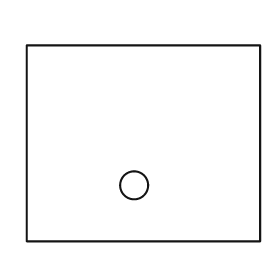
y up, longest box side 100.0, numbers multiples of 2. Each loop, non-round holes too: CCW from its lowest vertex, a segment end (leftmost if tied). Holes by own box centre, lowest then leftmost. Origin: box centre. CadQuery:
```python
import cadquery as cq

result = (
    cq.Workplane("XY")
    .moveTo(-50.0, -42.0)
    .lineTo(50.0, -42.0)
    .lineTo(50.0, 42.0)
    .lineTo(-50.0, 42.0)
    .close()
    .moveTo(-4.0, -18.0)
    .circle(6.0)
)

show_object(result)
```